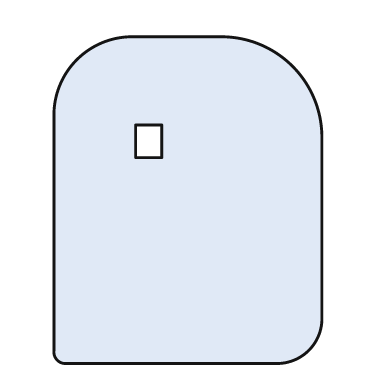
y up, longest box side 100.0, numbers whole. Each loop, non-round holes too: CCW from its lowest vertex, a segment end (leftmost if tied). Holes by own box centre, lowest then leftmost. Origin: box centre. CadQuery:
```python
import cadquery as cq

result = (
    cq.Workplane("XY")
    .moveTo(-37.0, -50.0)
    .lineTo(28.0, -50.0)
    .threePointArc((37.0, -46.0), (41.0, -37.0))
    .lineTo(41.0, 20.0)
    .threePointArc((32.0, 41.0), (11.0, 50.0))
    .lineTo(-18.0, 50.0)
    .threePointArc((-34.0, 43.0), (-41.0, 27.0))
    .lineTo(-41.0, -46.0)
    .threePointArc((-40.0, -49.0), (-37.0, -50.0))
    .close()
    .moveTo(-16.0, 13.0)
    .lineTo(-8.0, 13.0)
    .lineTo(-8.0, 23.0)
    .lineTo(-16.0, 23.0)
    .close()
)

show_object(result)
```